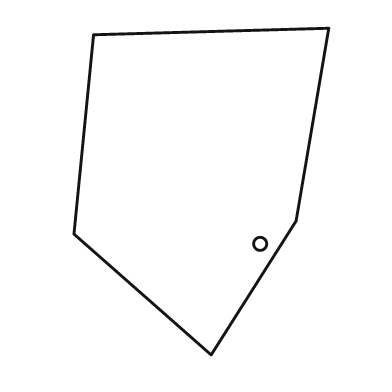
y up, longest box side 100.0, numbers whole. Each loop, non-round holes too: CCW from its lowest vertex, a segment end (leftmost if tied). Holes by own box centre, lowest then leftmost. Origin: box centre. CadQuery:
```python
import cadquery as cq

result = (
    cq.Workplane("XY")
    .moveTo(3.0, -50.0)
    .lineTo(29.0, -9.0)
    .lineTo(39.0, 50.0)
    .lineTo(-33.0, 48.0)
    .lineTo(-39.0, -13.0)
    .close()
    .moveTo(18.0, -16.0)
    .circle(2.0)
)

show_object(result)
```